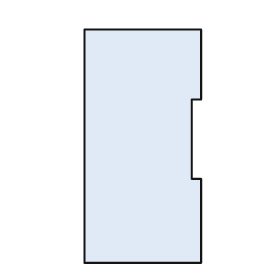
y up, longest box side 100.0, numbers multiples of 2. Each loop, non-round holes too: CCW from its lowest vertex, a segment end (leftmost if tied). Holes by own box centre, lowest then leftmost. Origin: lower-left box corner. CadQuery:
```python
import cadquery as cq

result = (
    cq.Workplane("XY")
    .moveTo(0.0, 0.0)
    .lineTo(50.0, 0.0)
    .lineTo(50.0, 36.0)
    .lineTo(46.0, 36.0)
    .lineTo(46.0, 70.0)
    .lineTo(50.0, 70.0)
    .lineTo(50.0, 100.0)
    .lineTo(0.0, 100.0)
    .close()
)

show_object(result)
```